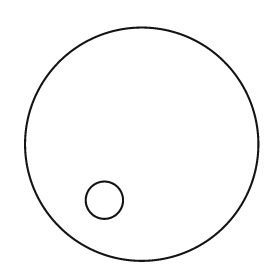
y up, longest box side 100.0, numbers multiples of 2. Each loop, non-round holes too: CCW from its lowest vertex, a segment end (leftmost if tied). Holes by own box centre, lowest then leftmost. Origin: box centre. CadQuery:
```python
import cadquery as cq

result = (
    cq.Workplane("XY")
    .moveTo(0.0, 0.0)
    .circle(50.0)
    .moveTo(-16.0, -24.0)
    .circle(8.0)
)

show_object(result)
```